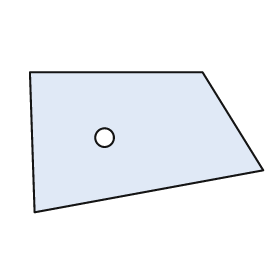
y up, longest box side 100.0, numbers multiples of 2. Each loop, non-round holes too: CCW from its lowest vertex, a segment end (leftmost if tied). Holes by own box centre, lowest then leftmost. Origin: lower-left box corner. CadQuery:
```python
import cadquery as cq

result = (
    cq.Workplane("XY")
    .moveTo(2.0, 0.0)
    .lineTo(100.0, 18.0)
    .lineTo(74.0, 60.0)
    .lineTo(0.0, 60.0)
    .close()
    .moveTo(32.0, 32.0)
    .circle(4.0)
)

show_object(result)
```